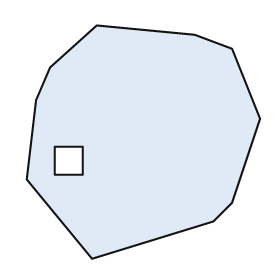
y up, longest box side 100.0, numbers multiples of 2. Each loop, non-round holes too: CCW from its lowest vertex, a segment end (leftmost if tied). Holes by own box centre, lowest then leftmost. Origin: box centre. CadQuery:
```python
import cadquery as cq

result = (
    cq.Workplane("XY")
    .moveTo(-22.0, -50.0)
    .lineTo(30.0, -34.0)
    .lineTo(38.0, -26.0)
    .lineTo(50.0, 10.0)
    .lineTo(38.0, 40.0)
    .lineTo(22.0, 46.0)
    .lineTo(-20.0, 50.0)
    .lineTo(-40.0, 32.0)
    .lineTo(-46.0, 18.0)
    .lineTo(-50.0, -16.0)
    .close()
    .moveTo(-38.0, -14.0)
    .lineTo(-26.0, -14.0)
    .lineTo(-26.0, -2.0)
    .lineTo(-38.0, -2.0)
    .close()
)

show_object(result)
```